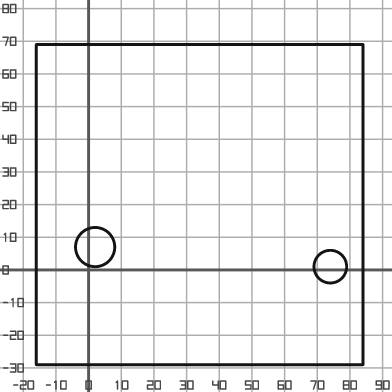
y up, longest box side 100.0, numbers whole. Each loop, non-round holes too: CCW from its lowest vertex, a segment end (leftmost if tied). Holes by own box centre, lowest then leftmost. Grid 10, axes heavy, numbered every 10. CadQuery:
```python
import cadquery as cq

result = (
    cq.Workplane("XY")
    .moveTo(-16.0, -29.0)
    .lineTo(84.0, -29.0)
    .lineTo(84.0, 69.0)
    .lineTo(-16.0, 69.0)
    .close()
    .moveTo(74.0, 1.0)
    .circle(5.0)
    .moveTo(2.0, 7.0)
    .circle(6.0)
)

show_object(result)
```